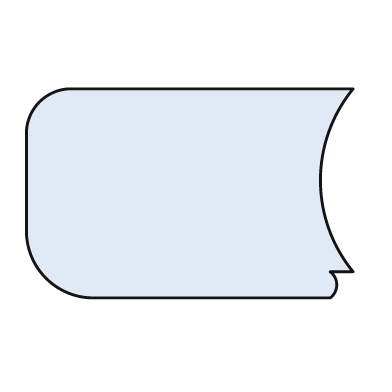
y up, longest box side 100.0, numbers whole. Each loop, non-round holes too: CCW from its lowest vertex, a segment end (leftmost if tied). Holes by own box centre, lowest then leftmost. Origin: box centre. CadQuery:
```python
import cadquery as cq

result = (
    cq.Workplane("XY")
    .moveTo(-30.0, -32.0)
    .lineTo(43.0, -32.0)
    .threePointArc((45.0, -28.0), (43.0, -24.0))
    .lineTo(50.0, -24.0)
    .threePointArc((40.0, 4.0), (50.0, 32.0))
    .lineTo(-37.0, 32.0)
    .threePointArc((-46.0, 28.0), (-50.0, 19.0))
    .lineTo(-50.0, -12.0)
    .threePointArc((-44.0, -26.0), (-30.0, -32.0))
    .close()
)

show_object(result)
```